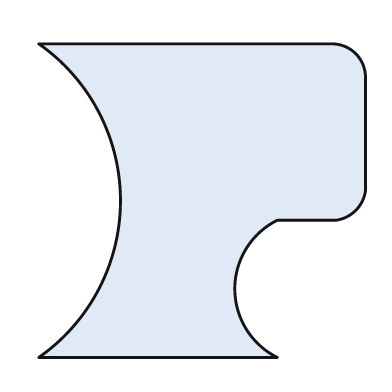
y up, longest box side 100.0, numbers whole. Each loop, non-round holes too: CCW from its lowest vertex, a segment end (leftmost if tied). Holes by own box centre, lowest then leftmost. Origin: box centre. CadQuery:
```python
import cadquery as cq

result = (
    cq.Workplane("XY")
    .moveTo(-50.0, -48.0)
    .lineTo(23.0, -48.0)
    .threePointArc((10.0, -27.0), (23.0, -6.0))
    .lineTo(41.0, -6.0)
    .threePointArc((47.0, -3.0), (50.0, 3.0))
    .lineTo(50.0, 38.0)
    .threePointArc((47.0, 45.0), (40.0, 48.0))
    .lineTo(-50.0, 48.0)
    .threePointArc((-25.0, 0.0), (-50.0, -48.0))
    .close()
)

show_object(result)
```